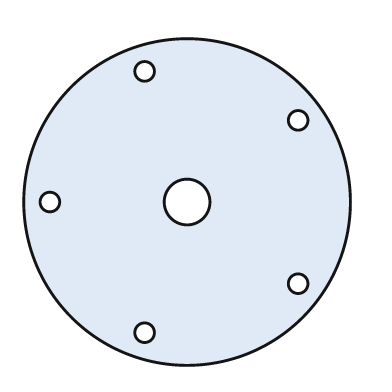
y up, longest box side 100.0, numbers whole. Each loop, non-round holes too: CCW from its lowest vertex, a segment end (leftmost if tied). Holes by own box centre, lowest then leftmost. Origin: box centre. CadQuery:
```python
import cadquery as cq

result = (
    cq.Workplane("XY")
    .moveTo(0.0, 0.0)
    .circle(50.0)
    .moveTo(-13.0, -40.0)
    .circle(3.0)
    .moveTo(34.0, -25.0)
    .circle(3.0)
    .moveTo(-42.0, 0.0)
    .circle(3.0)
    .moveTo(0.0, 0.0)
    .circle(7.0)
    .moveTo(34.0, 25.0)
    .circle(3.0)
    .moveTo(-13.0, 40.0)
    .circle(3.0)
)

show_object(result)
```